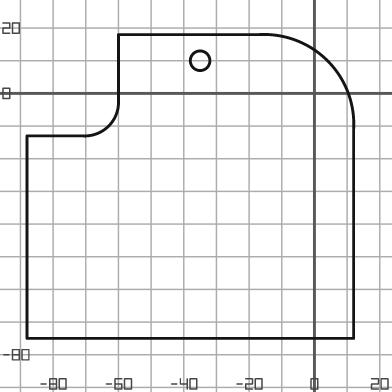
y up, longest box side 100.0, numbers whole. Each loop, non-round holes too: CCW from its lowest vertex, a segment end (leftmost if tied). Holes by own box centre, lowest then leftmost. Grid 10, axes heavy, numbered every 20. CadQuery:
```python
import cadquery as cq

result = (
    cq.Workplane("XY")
    .moveTo(-88.0, -75.0)
    .lineTo(12.0, -75.0)
    .lineTo(12.0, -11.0)
    .threePointArc((4.0, 10.0), (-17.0, 18.0))
    .lineTo(-60.0, 18.0)
    .lineTo(-60.0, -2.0)
    .threePointArc((-63.0, -10.0), (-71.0, -13.0))
    .lineTo(-88.0, -13.0)
    .close()
    .moveTo(-35.0, 10.0)
    .circle(3.0)
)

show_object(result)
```